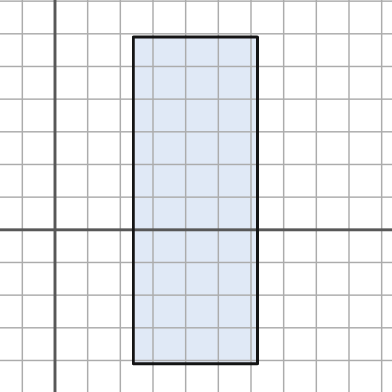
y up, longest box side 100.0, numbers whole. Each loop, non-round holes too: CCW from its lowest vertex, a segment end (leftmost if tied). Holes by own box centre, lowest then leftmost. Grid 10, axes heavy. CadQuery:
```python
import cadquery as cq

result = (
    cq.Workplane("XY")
    .moveTo(24.0, -41.0)
    .lineTo(62.0, -41.0)
    .lineTo(62.0, 59.0)
    .lineTo(24.0, 59.0)
    .close()
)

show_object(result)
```